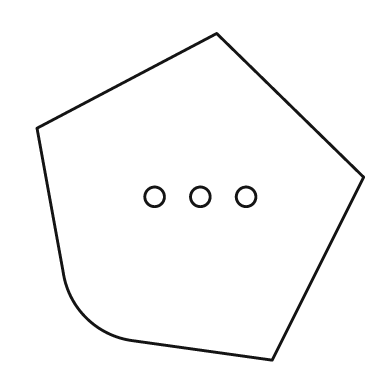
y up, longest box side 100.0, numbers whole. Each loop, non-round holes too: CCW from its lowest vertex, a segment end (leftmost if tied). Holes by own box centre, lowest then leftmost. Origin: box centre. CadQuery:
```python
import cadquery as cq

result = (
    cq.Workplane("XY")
    .moveTo(22.0, -50.0)
    .lineTo(50.0, 6.0)
    .lineTo(5.0, 50.0)
    .lineTo(-50.0, 21.0)
    .lineTo(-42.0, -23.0)
    .threePointArc((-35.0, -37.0), (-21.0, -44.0))
    .close()
    .moveTo(-14.0, 0.0)
    .circle(3.0)
    .moveTo(0.0, 0.0)
    .circle(3.0)
    .moveTo(14.0, 0.0)
    .circle(3.0)
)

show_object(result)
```